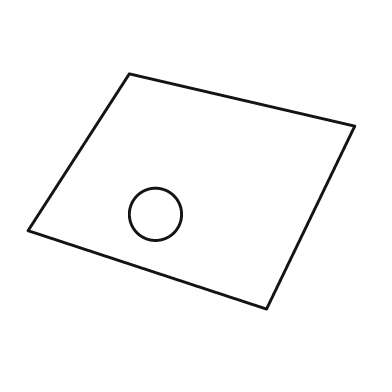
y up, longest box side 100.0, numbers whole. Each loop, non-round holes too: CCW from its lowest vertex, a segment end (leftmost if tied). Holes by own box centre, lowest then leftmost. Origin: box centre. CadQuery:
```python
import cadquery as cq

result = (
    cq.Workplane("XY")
    .moveTo(23.0, -36.0)
    .lineTo(50.0, 20.0)
    .lineTo(-19.0, 36.0)
    .lineTo(-50.0, -12.0)
    .close()
    .moveTo(-11.0, -7.0)
    .circle(8.0)
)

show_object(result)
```